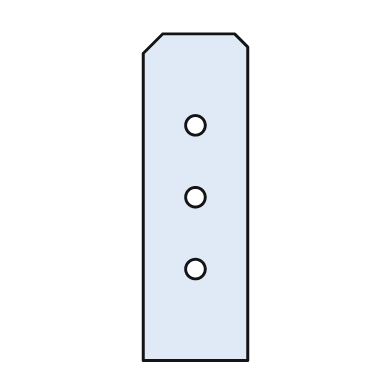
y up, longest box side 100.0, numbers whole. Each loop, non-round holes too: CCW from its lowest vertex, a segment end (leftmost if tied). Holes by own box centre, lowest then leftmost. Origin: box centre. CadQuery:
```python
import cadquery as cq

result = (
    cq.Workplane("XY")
    .moveTo(-16.0, -50.0)
    .lineTo(16.0, -50.0)
    .lineTo(16.0, 46.0)
    .lineTo(12.0, 50.0)
    .lineTo(-10.0, 50.0)
    .lineTo(-16.0, 44.0)
    .close()
    .moveTo(0.0, -22.0)
    .circle(3.0)
    .moveTo(0.0, 0.0)
    .circle(3.0)
    .moveTo(0.0, 22.0)
    .circle(3.0)
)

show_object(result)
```